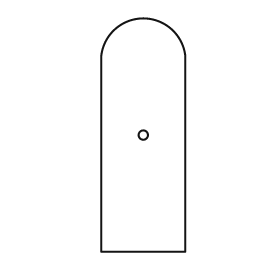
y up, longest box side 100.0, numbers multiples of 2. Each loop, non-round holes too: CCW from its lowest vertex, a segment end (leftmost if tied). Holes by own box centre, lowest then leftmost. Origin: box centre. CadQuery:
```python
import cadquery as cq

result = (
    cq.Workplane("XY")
    .moveTo(-18.0, -50.0)
    .lineTo(18.0, -50.0)
    .lineTo(18.0, 34.0)
    .threePointArc((0.0, 50.0), (-18.0, 34.0))
    .close()
    .moveTo(0.0, 0.0)
    .circle(2.0)
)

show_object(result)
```